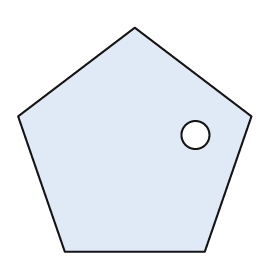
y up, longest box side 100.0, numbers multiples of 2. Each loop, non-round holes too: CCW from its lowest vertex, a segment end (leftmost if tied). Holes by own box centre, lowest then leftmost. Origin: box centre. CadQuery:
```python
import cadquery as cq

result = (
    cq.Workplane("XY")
    .moveTo(-30.0, -48.0)
    .lineTo(30.0, -48.0)
    .lineTo(50.0, 10.0)
    .lineTo(0.0, 48.0)
    .lineTo(-50.0, 10.0)
    .close()
    .moveTo(26.0, 2.0)
    .circle(6.0)
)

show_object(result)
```